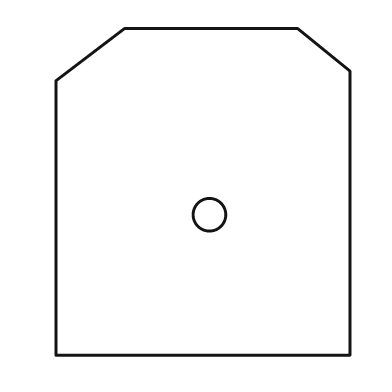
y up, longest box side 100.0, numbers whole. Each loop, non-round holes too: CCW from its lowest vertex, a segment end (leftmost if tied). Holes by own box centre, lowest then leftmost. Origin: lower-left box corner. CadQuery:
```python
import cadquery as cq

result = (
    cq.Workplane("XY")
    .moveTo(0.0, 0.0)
    .lineTo(90.0, 0.0)
    .lineTo(90.0, 87.0)
    .lineTo(74.0, 100.0)
    .lineTo(21.0, 100.0)
    .lineTo(0.0, 84.0)
    .close()
    .moveTo(47.0, 43.0)
    .circle(5.0)
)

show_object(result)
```